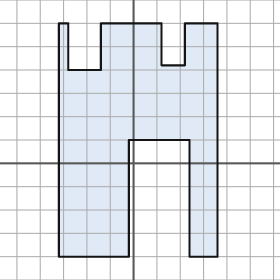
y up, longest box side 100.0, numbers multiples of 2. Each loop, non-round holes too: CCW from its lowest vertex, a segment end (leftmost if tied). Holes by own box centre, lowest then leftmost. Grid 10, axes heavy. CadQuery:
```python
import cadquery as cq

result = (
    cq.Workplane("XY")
    .moveTo(-32.0, -40.0)
    .lineTo(-2.0, -40.0)
    .lineTo(-2.0, 10.0)
    .lineTo(24.0, 10.0)
    .lineTo(24.0, -40.0)
    .lineTo(36.0, -40.0)
    .lineTo(36.0, 60.0)
    .lineTo(22.0, 60.0)
    .lineTo(22.0, 42.0)
    .lineTo(12.0, 42.0)
    .lineTo(12.0, 60.0)
    .lineTo(-14.0, 60.0)
    .lineTo(-14.0, 40.0)
    .lineTo(-28.0, 40.0)
    .lineTo(-28.0, 60.0)
    .lineTo(-32.0, 60.0)
    .close()
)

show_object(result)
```